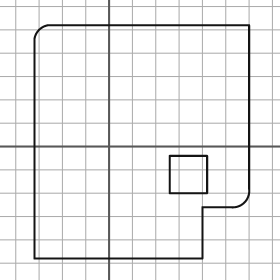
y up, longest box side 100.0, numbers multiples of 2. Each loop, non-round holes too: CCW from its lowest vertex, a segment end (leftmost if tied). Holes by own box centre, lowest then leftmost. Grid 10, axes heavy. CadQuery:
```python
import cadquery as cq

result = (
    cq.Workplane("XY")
    .moveTo(-32.0, -48.0)
    .lineTo(40.0, -48.0)
    .lineTo(40.0, -26.0)
    .lineTo(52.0, -26.0)
    .threePointArc((58.0, -24.0), (60.0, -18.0))
    .lineTo(60.0, 52.0)
    .lineTo(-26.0, 52.0)
    .threePointArc((-30.0, 50.0), (-32.0, 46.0))
    .close()
    .moveTo(26.0, -20.0)
    .lineTo(42.0, -20.0)
    .lineTo(42.0, -4.0)
    .lineTo(26.0, -4.0)
    .close()
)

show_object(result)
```